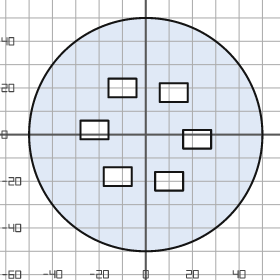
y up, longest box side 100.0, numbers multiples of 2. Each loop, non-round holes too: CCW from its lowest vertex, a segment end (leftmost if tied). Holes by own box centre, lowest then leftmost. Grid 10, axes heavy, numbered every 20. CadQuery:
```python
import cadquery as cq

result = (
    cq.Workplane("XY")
    .moveTo(0.0, 0.0)
    .circle(50.0)
    .moveTo(4.0, -24.0)
    .lineTo(16.0, -24.0)
    .lineTo(16.0, -16.0)
    .lineTo(4.0, -16.0)
    .close()
    .moveTo(-18.0, -22.0)
    .lineTo(-6.0, -22.0)
    .lineTo(-6.0, -14.0)
    .lineTo(-18.0, -14.0)
    .close()
    .moveTo(16.0, -6.0)
    .lineTo(28.0, -6.0)
    .lineTo(28.0, 2.0)
    .lineTo(16.0, 2.0)
    .close()
    .moveTo(-28.0, -2.0)
    .lineTo(-16.0, -2.0)
    .lineTo(-16.0, 6.0)
    .lineTo(-28.0, 6.0)
    .close()
    .moveTo(6.0, 14.0)
    .lineTo(18.0, 14.0)
    .lineTo(18.0, 22.0)
    .lineTo(6.0, 22.0)
    .close()
    .moveTo(-16.0, 16.0)
    .lineTo(-4.0, 16.0)
    .lineTo(-4.0, 24.0)
    .lineTo(-16.0, 24.0)
    .close()
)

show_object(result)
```